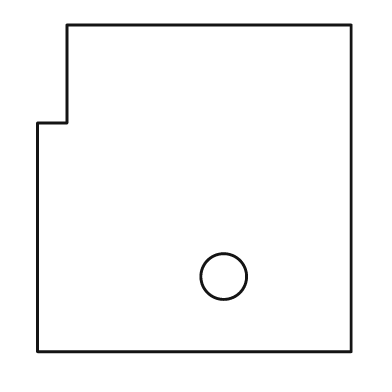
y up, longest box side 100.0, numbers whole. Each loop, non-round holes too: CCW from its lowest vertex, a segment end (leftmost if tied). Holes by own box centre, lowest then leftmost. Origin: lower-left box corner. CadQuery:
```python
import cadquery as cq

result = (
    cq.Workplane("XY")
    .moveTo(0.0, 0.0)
    .lineTo(96.0, 0.0)
    .lineTo(96.0, 100.0)
    .lineTo(9.0, 100.0)
    .lineTo(9.0, 70.0)
    .lineTo(0.0, 70.0)
    .close()
    .moveTo(57.0, 23.0)
    .circle(7.0)
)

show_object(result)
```